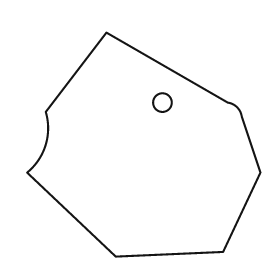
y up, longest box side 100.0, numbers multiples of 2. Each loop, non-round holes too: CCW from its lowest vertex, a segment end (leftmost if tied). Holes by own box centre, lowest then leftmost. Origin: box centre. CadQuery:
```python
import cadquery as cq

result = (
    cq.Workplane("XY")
    .moveTo(-12.0, -48.0)
    .lineTo(34.0, -46.0)
    .lineTo(50.0, -12.0)
    .lineTo(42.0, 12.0)
    .threePointArc((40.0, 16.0), (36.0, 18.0))
    .lineTo(-16.0, 48.0)
    .lineTo(-42.0, 14.0)
    .threePointArc((-42.0, 0.0), (-50.0, -12.0))
    .close()
    .moveTo(8.0, 18.0)
    .circle(4.0)
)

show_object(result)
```